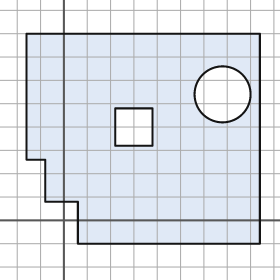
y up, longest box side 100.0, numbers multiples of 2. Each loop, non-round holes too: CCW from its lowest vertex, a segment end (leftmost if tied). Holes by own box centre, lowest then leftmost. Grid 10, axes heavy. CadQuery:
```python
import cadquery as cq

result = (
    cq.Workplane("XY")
    .moveTo(6.0, -10.0)
    .lineTo(84.0, -10.0)
    .lineTo(84.0, 80.0)
    .lineTo(-16.0, 80.0)
    .lineTo(-16.0, 26.0)
    .lineTo(-8.0, 26.0)
    .lineTo(-8.0, 8.0)
    .lineTo(6.0, 8.0)
    .close()
    .moveTo(22.0, 32.0)
    .lineTo(38.0, 32.0)
    .lineTo(38.0, 48.0)
    .lineTo(22.0, 48.0)
    .close()
    .moveTo(68.0, 54.0)
    .circle(12.0)
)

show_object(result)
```